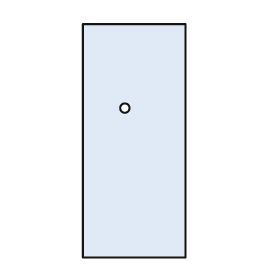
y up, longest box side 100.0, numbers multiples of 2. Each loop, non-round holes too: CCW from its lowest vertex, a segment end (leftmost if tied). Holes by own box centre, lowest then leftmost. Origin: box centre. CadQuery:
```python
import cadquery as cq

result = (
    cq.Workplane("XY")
    .moveTo(-22.0, -50.0)
    .lineTo(22.0, -50.0)
    .lineTo(22.0, 50.0)
    .lineTo(-22.0, 50.0)
    .close()
    .moveTo(-4.0, 14.0)
    .circle(2.0)
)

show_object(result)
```